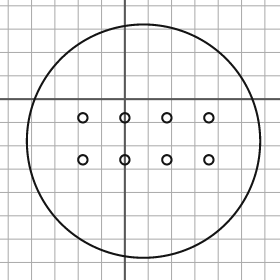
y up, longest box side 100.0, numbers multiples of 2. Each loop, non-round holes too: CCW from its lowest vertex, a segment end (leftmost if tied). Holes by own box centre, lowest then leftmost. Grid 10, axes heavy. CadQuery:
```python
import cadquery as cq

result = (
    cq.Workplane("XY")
    .moveTo(8.0, -18.0)
    .circle(50.0)
    .moveTo(-18.0, -26.0)
    .circle(2.0)
    .moveTo(0.0, -26.0)
    .circle(2.0)
    .moveTo(18.0, -26.0)
    .circle(2.0)
    .moveTo(36.0, -26.0)
    .circle(2.0)
    .moveTo(-18.0, -8.0)
    .circle(2.0)
    .moveTo(0.0, -8.0)
    .circle(2.0)
    .moveTo(18.0, -8.0)
    .circle(2.0)
    .moveTo(36.0, -8.0)
    .circle(2.0)
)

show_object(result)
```